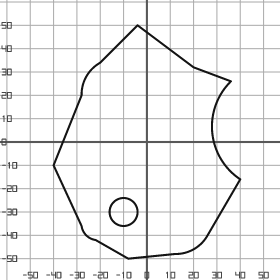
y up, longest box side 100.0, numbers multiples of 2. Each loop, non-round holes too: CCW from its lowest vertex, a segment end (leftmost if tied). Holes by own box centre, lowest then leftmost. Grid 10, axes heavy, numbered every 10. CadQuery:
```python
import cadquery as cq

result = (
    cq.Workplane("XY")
    .moveTo(-8.0, -50.0)
    .lineTo(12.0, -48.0)
    .threePointArc((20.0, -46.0), (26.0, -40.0))
    .lineTo(40.0, -16.0)
    .threePointArc((28.0, 4.0), (36.0, 26.0))
    .lineTo(20.0, 32.0)
    .lineTo(-4.0, 50.0)
    .lineTo(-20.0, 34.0)
    .threePointArc((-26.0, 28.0), (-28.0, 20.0))
    .lineTo(-40.0, -10.0)
    .lineTo(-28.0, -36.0)
    .threePointArc((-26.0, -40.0), (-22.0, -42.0))
    .close()
    .moveTo(-10.0, -30.0)
    .circle(6.0)
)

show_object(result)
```